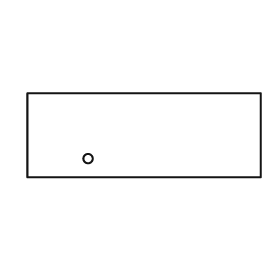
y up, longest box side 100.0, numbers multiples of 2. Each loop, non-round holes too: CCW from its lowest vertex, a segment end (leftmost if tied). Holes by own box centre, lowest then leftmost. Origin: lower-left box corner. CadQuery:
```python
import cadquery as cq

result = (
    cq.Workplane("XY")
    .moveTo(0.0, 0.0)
    .lineTo(100.0, 0.0)
    .lineTo(100.0, 36.0)
    .lineTo(0.0, 36.0)
    .close()
    .moveTo(26.0, 8.0)
    .circle(2.0)
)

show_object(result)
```